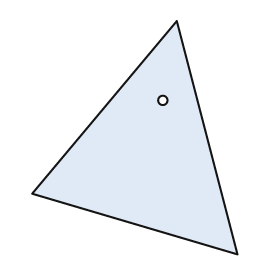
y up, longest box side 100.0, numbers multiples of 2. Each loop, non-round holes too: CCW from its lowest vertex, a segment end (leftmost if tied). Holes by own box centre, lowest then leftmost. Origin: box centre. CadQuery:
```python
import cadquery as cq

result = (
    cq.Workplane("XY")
    .moveTo(44.0, -50.0)
    .lineTo(18.0, 50.0)
    .lineTo(-44.0, -24.0)
    .close()
    .moveTo(12.0, 16.0)
    .circle(2.0)
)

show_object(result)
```